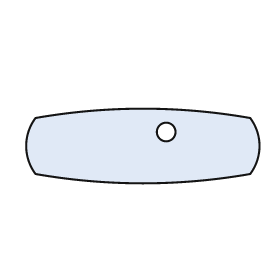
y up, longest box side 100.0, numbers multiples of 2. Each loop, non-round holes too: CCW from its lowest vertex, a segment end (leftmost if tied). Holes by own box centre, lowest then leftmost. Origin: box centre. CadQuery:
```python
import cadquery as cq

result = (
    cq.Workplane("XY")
    .moveTo(-46.0, -12.0)
    .threePointArc((0.0, -16.0), (46.0, -12.0))
    .threePointArc((50.0, 0.0), (46.0, 12.0))
    .threePointArc((0.0, 16.0), (-46.0, 12.0))
    .threePointArc((-50.0, 0.0), (-46.0, -12.0))
    .close()
    .moveTo(10.0, 6.0)
    .circle(4.0)
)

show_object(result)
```